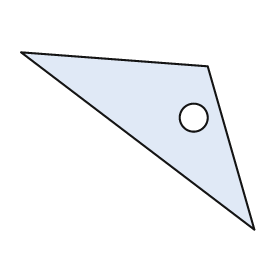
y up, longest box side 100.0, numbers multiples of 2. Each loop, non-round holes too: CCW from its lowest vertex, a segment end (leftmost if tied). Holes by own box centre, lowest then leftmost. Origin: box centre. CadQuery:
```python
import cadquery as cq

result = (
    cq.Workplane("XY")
    .moveTo(50.0, -38.0)
    .lineTo(30.0, 32.0)
    .lineTo(-50.0, 38.0)
    .close()
    .moveTo(24.0, 10.0)
    .circle(6.0)
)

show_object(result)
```